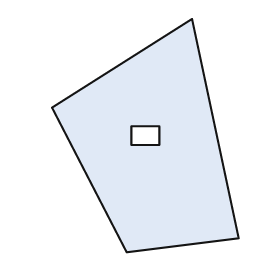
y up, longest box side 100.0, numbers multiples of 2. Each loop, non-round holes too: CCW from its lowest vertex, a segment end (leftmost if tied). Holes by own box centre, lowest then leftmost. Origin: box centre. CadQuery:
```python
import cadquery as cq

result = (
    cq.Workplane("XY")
    .moveTo(-8.0, -50.0)
    .lineTo(40.0, -44.0)
    .lineTo(20.0, 50.0)
    .lineTo(-40.0, 12.0)
    .close()
    .moveTo(-6.0, -4.0)
    .lineTo(6.0, -4.0)
    .lineTo(6.0, 4.0)
    .lineTo(-6.0, 4.0)
    .close()
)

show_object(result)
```